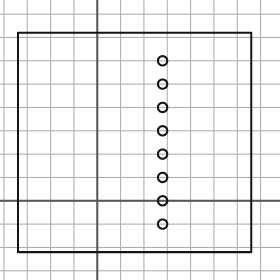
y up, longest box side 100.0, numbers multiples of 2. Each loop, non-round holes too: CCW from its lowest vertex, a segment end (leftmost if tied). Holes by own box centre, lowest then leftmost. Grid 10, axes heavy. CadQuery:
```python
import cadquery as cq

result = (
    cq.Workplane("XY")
    .moveTo(-34.0, -22.0)
    .lineTo(66.0, -22.0)
    .lineTo(66.0, 72.0)
    .lineTo(-34.0, 72.0)
    .close()
    .moveTo(28.0, -10.0)
    .circle(2.0)
    .moveTo(28.0, 0.0)
    .circle(2.0)
    .moveTo(28.0, 10.0)
    .circle(2.0)
    .moveTo(28.0, 20.0)
    .circle(2.0)
    .moveTo(28.0, 30.0)
    .circle(2.0)
    .moveTo(28.0, 40.0)
    .circle(2.0)
    .moveTo(28.0, 50.0)
    .circle(2.0)
    .moveTo(28.0, 60.0)
    .circle(2.0)
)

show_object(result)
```